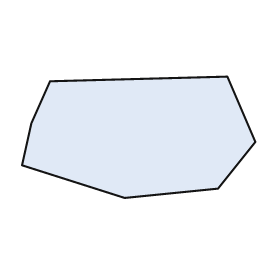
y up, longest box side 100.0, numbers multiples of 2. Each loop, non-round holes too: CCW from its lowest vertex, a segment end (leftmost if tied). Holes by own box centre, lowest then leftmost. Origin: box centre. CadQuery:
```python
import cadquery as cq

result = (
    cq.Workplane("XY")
    .moveTo(-6.0, -26.0)
    .lineTo(34.0, -22.0)
    .lineTo(50.0, -2.0)
    .lineTo(38.0, 26.0)
    .lineTo(-38.0, 24.0)
    .lineTo(-46.0, 6.0)
    .lineTo(-50.0, -12.0)
    .close()
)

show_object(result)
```